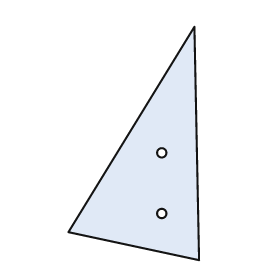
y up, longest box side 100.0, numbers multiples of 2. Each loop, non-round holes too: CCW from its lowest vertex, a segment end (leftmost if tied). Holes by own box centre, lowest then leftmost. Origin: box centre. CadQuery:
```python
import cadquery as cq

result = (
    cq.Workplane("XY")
    .moveTo(28.0, -50.0)
    .lineTo(26.0, 50.0)
    .lineTo(-28.0, -38.0)
    .close()
    .moveTo(12.0, -30.0)
    .circle(2.0)
    .moveTo(12.0, -4.0)
    .circle(2.0)
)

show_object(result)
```